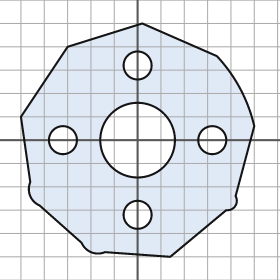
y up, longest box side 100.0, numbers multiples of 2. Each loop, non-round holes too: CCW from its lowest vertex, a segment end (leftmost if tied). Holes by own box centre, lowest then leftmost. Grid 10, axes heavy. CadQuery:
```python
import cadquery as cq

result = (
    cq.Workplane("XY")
    .moveTo(14.0, -50.0)
    .lineTo(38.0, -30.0)
    .threePointArc((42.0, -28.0), (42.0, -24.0))
    .lineTo(50.0, 6.0)
    .threePointArc((44.0, 22.0), (34.0, 36.0))
    .lineTo(2.0, 50.0)
    .lineTo(-30.0, 40.0)
    .lineTo(-50.0, 10.0)
    .lineTo(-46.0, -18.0)
    .threePointArc((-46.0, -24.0), (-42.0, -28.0))
    .lineTo(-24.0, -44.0)
    .threePointArc((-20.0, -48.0), (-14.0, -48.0))
    .close()
    .moveTo(0.0, -32.0)
    .circle(6.0)
    .moveTo(-32.0, 0.0)
    .circle(6.0)
    .moveTo(0.0, 0.0)
    .circle(16.0)
    .moveTo(32.0, 0.0)
    .circle(6.0)
    .moveTo(0.0, 32.0)
    .circle(6.0)
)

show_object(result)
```